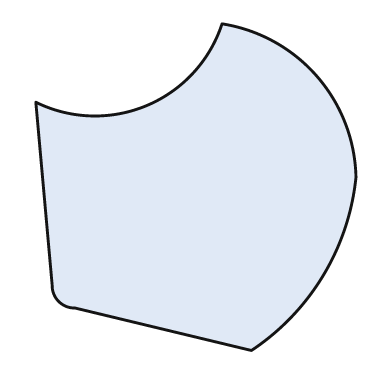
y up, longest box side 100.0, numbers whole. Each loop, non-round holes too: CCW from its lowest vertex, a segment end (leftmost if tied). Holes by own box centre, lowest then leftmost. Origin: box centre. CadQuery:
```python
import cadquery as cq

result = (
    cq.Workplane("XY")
    .moveTo(17.0, -50.0)
    .threePointArc((39.0, -27.0), (49.0, 3.0))
    .threePointArc((37.0, 34.0), (8.0, 50.0))
    .threePointArc((-15.0, 25.0), (-49.0, 26.0))
    .lineTo(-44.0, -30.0)
    .threePointArc((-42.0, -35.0), (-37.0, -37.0))
    .close()
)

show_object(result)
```